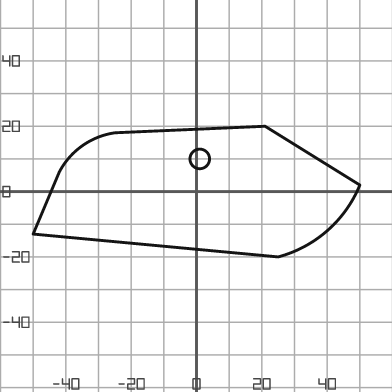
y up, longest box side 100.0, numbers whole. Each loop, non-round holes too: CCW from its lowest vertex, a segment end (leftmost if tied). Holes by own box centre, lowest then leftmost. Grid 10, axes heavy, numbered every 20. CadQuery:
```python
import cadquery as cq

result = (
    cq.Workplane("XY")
    .moveTo(25.0, -20.0)
    .threePointArc((40.0, -12.0), (50.0, 2.0))
    .lineTo(21.0, 20.0)
    .lineTo(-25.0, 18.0)
    .threePointArc((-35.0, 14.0), (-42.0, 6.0))
    .lineTo(-50.0, -13.0)
    .close()
    .moveTo(1.0, 10.0)
    .circle(3.0)
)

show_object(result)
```